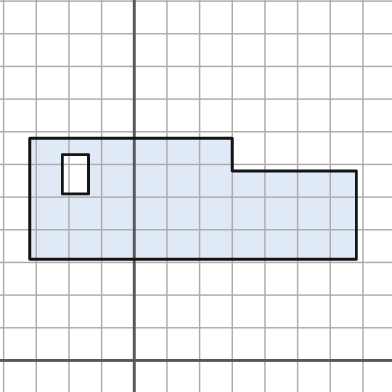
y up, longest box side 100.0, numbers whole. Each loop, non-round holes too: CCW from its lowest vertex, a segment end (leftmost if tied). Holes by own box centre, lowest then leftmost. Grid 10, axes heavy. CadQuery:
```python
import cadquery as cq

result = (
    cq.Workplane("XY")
    .moveTo(-32.0, 31.0)
    .lineTo(68.0, 31.0)
    .lineTo(68.0, 58.0)
    .lineTo(30.0, 58.0)
    .lineTo(30.0, 68.0)
    .lineTo(-32.0, 68.0)
    .close()
    .moveTo(-22.0, 51.0)
    .lineTo(-14.0, 51.0)
    .lineTo(-14.0, 63.0)
    .lineTo(-22.0, 63.0)
    .close()
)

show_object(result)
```